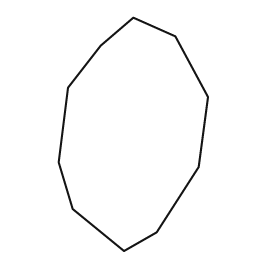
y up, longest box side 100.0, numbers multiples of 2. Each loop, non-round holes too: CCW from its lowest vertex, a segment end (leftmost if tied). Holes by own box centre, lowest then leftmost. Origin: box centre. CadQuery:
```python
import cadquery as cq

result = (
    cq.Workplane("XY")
    .moveTo(-4.0, -50.0)
    .lineTo(10.0, -42.0)
    .lineTo(28.0, -14.0)
    .lineTo(32.0, 16.0)
    .lineTo(18.0, 42.0)
    .lineTo(0.0, 50.0)
    .lineTo(-14.0, 38.0)
    .lineTo(-28.0, 20.0)
    .lineTo(-32.0, -12.0)
    .lineTo(-26.0, -32.0)
    .close()
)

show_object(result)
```